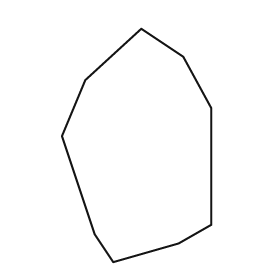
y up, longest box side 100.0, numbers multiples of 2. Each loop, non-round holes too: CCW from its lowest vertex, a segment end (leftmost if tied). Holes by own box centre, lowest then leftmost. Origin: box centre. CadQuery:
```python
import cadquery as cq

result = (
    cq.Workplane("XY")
    .moveTo(-10.0, -50.0)
    .lineTo(18.0, -42.0)
    .lineTo(32.0, -34.0)
    .lineTo(32.0, 16.0)
    .lineTo(20.0, 38.0)
    .lineTo(2.0, 50.0)
    .lineTo(-22.0, 28.0)
    .lineTo(-32.0, 4.0)
    .lineTo(-18.0, -38.0)
    .close()
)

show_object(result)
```